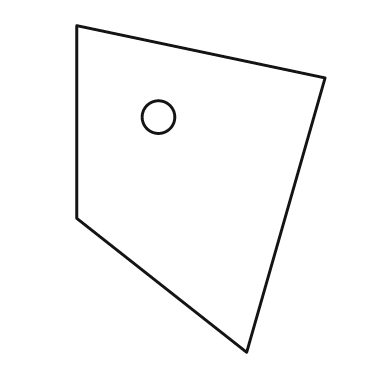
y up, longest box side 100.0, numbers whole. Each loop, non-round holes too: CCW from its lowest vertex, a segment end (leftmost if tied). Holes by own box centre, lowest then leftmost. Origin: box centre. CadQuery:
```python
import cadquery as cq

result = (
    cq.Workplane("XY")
    .moveTo(14.0, -50.0)
    .lineTo(38.0, 34.0)
    .lineTo(-38.0, 50.0)
    .lineTo(-38.0, -9.0)
    .close()
    .moveTo(-13.0, 22.0)
    .circle(5.0)
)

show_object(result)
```